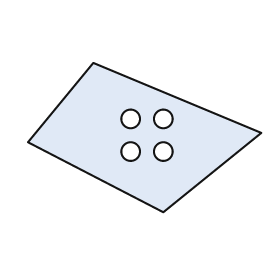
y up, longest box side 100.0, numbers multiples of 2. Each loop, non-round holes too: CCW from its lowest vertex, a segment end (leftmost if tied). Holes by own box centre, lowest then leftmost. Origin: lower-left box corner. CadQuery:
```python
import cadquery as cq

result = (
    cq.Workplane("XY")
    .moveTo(58.0, 0.0)
    .lineTo(100.0, 34.0)
    .lineTo(28.0, 64.0)
    .lineTo(0.0, 30.0)
    .close()
    .moveTo(44.0, 26.0)
    .circle(4.0)
    .moveTo(58.0, 26.0)
    .circle(4.0)
    .moveTo(44.0, 40.0)
    .circle(4.0)
    .moveTo(58.0, 40.0)
    .circle(4.0)
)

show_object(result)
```